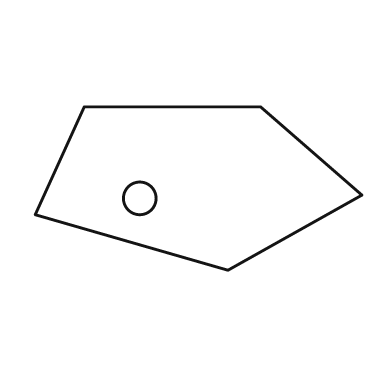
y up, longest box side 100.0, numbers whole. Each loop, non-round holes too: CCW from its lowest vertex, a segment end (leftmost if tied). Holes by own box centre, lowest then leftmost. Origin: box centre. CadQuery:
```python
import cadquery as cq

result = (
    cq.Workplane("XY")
    .moveTo(9.0, -25.0)
    .lineTo(50.0, -2.0)
    .lineTo(19.0, 25.0)
    .lineTo(-35.0, 25.0)
    .lineTo(-50.0, -8.0)
    .close()
    .moveTo(-18.0, -3.0)
    .circle(5.0)
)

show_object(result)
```